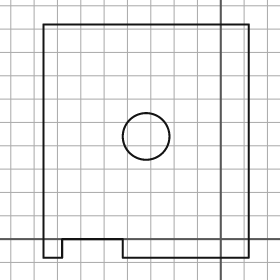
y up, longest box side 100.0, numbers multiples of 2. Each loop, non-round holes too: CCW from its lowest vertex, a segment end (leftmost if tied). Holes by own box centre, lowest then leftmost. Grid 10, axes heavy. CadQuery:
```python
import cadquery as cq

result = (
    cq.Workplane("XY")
    .moveTo(-76.0, -8.0)
    .lineTo(-68.0, -8.0)
    .lineTo(-68.0, 0.0)
    .lineTo(-42.0, 0.0)
    .lineTo(-42.0, -8.0)
    .lineTo(12.0, -8.0)
    .lineTo(12.0, 92.0)
    .lineTo(-76.0, 92.0)
    .close()
    .moveTo(-32.0, 44.0)
    .circle(10.0)
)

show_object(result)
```